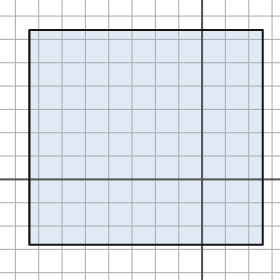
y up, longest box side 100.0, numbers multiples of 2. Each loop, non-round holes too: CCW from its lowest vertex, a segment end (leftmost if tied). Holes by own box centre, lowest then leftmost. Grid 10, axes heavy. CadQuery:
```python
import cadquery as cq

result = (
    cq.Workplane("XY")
    .moveTo(-74.0, -28.0)
    .lineTo(26.0, -28.0)
    .lineTo(26.0, 64.0)
    .lineTo(-74.0, 64.0)
    .close()
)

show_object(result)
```